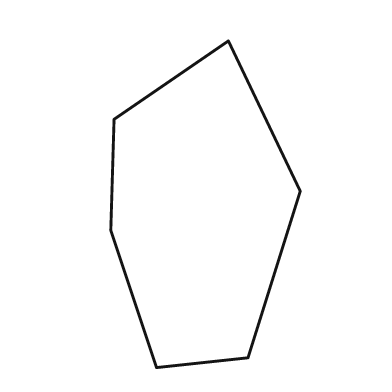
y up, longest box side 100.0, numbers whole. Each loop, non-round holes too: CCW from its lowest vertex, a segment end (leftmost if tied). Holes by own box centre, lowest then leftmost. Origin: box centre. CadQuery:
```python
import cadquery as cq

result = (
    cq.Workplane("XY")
    .moveTo(-15.0, -50.0)
    .lineTo(13.0, -47.0)
    .lineTo(29.0, 4.0)
    .lineTo(7.0, 50.0)
    .lineTo(-28.0, 26.0)
    .lineTo(-29.0, -8.0)
    .close()
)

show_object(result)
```